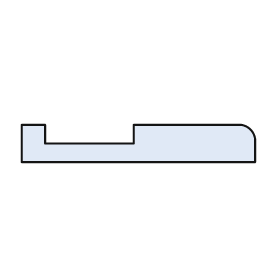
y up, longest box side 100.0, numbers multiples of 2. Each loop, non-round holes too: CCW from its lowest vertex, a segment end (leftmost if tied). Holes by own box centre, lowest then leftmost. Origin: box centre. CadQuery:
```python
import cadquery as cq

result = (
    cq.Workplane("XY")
    .moveTo(-50.0, -8.0)
    .lineTo(50.0, -8.0)
    .lineTo(50.0, 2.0)
    .threePointArc((48.0, 6.0), (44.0, 8.0))
    .lineTo(-2.0, 8.0)
    .lineTo(-2.0, 0.0)
    .lineTo(-40.0, 0.0)
    .lineTo(-40.0, 8.0)
    .lineTo(-50.0, 8.0)
    .close()
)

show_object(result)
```